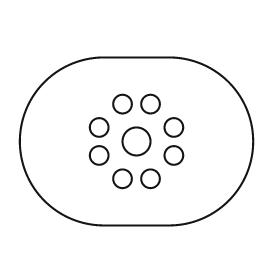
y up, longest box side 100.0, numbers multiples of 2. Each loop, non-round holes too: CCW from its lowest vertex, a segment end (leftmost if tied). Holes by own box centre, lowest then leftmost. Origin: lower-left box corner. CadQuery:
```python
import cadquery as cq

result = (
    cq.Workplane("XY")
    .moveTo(36.0, 0.0)
    .lineTo(64.0, 0.0)
    .threePointArc((100.0, 36.0), (64.0, 72.0))
    .lineTo(36.0, 72.0)
    .threePointArc((0.0, 36.0), (36.0, 0.0))
    .close()
    .moveTo(44.0, 20.0)
    .circle(4.0)
    .moveTo(56.0, 20.0)
    .circle(4.0)
    .moveTo(34.0, 30.0)
    .circle(4.0)
    .moveTo(66.0, 30.0)
    .circle(4.0)
    .moveTo(50.0, 36.0)
    .circle(6.0)
    .moveTo(34.0, 42.0)
    .circle(4.0)
    .moveTo(66.0, 42.0)
    .circle(4.0)
    .moveTo(44.0, 52.0)
    .circle(4.0)
    .moveTo(56.0, 52.0)
    .circle(4.0)
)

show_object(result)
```